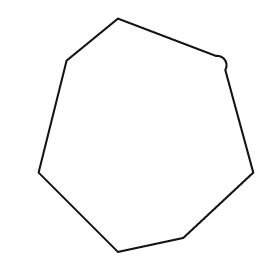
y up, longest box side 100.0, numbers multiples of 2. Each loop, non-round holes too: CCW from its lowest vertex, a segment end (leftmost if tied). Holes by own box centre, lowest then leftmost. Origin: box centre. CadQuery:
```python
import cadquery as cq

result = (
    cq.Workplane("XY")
    .moveTo(-12.0, -50.0)
    .lineTo(16.0, -44.0)
    .lineTo(46.0, -16.0)
    .lineTo(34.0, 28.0)
    .threePointArc((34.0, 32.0), (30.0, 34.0))
    .lineTo(-12.0, 50.0)
    .lineTo(-34.0, 32.0)
    .lineTo(-46.0, -16.0)
    .close()
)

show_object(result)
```